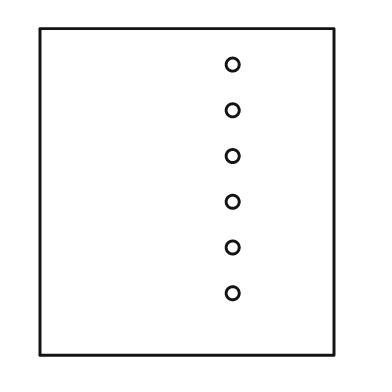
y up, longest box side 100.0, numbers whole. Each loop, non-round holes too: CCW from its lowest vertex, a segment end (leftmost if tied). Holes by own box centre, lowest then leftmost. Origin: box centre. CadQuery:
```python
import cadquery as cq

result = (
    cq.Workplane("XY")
    .moveTo(-45.0, -50.0)
    .lineTo(45.0, -50.0)
    .lineTo(45.0, 50.0)
    .lineTo(-45.0, 50.0)
    .close()
    .moveTo(14.0, -31.0)
    .circle(2.0)
    .moveTo(14.0, -17.0)
    .circle(2.0)
    .moveTo(14.0, -3.0)
    .circle(2.0)
    .moveTo(14.0, 11.0)
    .circle(2.0)
    .moveTo(14.0, 25.0)
    .circle(2.0)
    .moveTo(14.0, 39.0)
    .circle(2.0)
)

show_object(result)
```